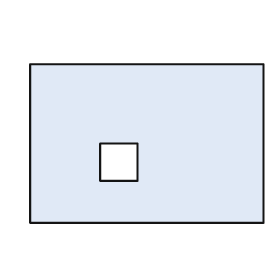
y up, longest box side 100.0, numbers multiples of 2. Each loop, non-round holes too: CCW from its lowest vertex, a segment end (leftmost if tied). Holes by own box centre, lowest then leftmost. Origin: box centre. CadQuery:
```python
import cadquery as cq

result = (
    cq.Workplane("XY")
    .moveTo(-50.0, -34.0)
    .lineTo(50.0, -34.0)
    .lineTo(50.0, 34.0)
    .lineTo(-50.0, 34.0)
    .close()
    .moveTo(-20.0, -16.0)
    .lineTo(-4.0, -16.0)
    .lineTo(-4.0, 0.0)
    .lineTo(-20.0, 0.0)
    .close()
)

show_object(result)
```